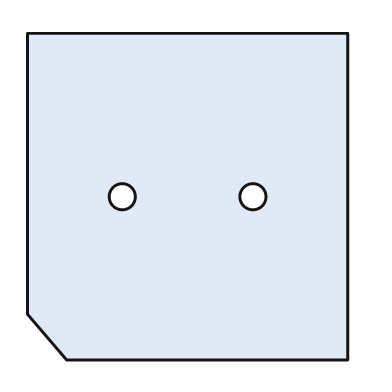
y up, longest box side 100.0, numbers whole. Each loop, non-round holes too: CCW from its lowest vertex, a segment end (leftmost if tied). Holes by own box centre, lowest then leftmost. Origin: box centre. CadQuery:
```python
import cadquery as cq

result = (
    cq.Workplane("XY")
    .moveTo(-37.0, -50.0)
    .lineTo(49.0, -50.0)
    .lineTo(49.0, 50.0)
    .lineTo(-49.0, 50.0)
    .lineTo(-49.0, -36.0)
    .close()
    .moveTo(-20.0, 0.0)
    .circle(4.0)
    .moveTo(20.0, 0.0)
    .circle(4.0)
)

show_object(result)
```